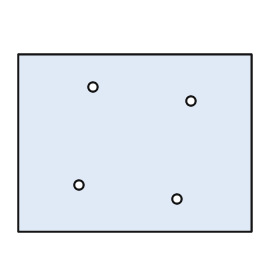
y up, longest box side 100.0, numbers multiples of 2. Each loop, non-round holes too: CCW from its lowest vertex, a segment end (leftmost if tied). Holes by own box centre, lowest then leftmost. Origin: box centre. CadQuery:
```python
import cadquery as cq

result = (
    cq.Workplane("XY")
    .moveTo(-50.0, -38.0)
    .lineTo(50.0, -38.0)
    .lineTo(50.0, 38.0)
    .lineTo(-50.0, 38.0)
    .close()
    .moveTo(18.0, -24.0)
    .circle(2.0)
    .moveTo(-24.0, -18.0)
    .circle(2.0)
    .moveTo(24.0, 18.0)
    .circle(2.0)
    .moveTo(-18.0, 24.0)
    .circle(2.0)
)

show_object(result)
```